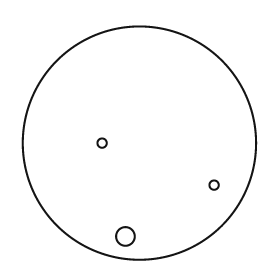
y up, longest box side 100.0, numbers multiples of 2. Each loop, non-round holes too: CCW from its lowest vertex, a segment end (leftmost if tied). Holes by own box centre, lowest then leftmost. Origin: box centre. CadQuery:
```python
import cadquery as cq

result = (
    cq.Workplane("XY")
    .moveTo(0.0, 0.0)
    .circle(50.0)
    .moveTo(-6.0, -40.0)
    .circle(4.0)
    .moveTo(32.0, -18.0)
    .circle(2.0)
    .moveTo(-16.0, 0.0)
    .circle(2.0)
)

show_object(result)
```